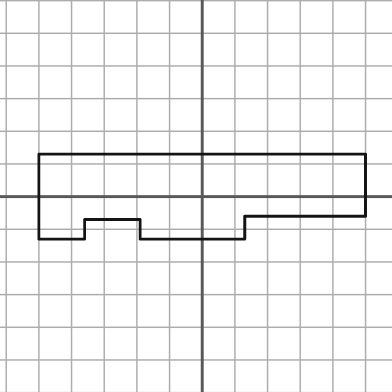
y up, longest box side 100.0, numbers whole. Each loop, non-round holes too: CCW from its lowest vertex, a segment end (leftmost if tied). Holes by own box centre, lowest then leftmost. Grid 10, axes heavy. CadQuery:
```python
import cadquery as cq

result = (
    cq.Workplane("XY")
    .moveTo(-50.0, -13.0)
    .lineTo(-36.0, -13.0)
    .lineTo(-36.0, -7.0)
    .lineTo(-19.0, -7.0)
    .lineTo(-19.0, -13.0)
    .lineTo(13.0, -13.0)
    .lineTo(13.0, -6.0)
    .lineTo(50.0, -6.0)
    .lineTo(50.0, 13.0)
    .lineTo(-50.0, 13.0)
    .close()
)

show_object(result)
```